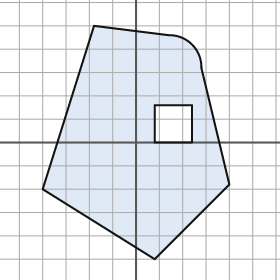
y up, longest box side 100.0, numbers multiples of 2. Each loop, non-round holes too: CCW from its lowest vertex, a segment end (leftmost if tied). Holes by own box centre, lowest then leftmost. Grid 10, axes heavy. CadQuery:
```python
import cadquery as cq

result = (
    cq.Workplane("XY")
    .moveTo(8.0, -50.0)
    .lineTo(40.0, -18.0)
    .lineTo(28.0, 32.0)
    .threePointArc((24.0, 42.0), (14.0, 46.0))
    .lineTo(-18.0, 50.0)
    .lineTo(-40.0, -20.0)
    .close()
    .moveTo(8.0, 0.0)
    .lineTo(24.0, 0.0)
    .lineTo(24.0, 16.0)
    .lineTo(8.0, 16.0)
    .close()
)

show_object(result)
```